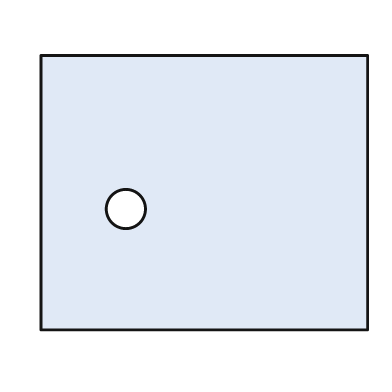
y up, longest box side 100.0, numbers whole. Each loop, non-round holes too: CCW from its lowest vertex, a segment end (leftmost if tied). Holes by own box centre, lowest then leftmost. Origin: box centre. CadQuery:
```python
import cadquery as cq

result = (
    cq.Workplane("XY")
    .moveTo(-50.0, -42.0)
    .lineTo(50.0, -42.0)
    .lineTo(50.0, 42.0)
    .lineTo(-50.0, 42.0)
    .close()
    .moveTo(-24.0, -5.0)
    .circle(6.0)
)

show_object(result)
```